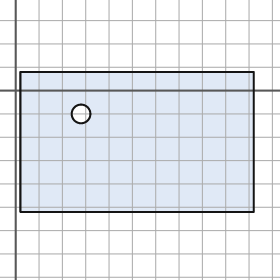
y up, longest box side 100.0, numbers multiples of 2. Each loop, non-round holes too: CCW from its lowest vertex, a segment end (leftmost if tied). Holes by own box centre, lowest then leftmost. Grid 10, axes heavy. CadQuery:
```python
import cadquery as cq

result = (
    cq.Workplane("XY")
    .moveTo(2.0, -52.0)
    .lineTo(102.0, -52.0)
    .lineTo(102.0, 8.0)
    .lineTo(2.0, 8.0)
    .close()
    .moveTo(28.0, -10.0)
    .circle(4.0)
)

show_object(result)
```